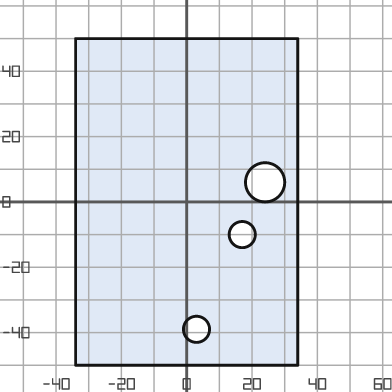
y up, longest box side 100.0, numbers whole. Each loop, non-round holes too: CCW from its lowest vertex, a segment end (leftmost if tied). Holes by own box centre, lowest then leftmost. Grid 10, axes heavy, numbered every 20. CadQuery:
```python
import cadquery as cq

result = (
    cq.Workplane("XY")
    .moveTo(-34.0, -50.0)
    .lineTo(34.0, -50.0)
    .lineTo(34.0, 50.0)
    .lineTo(-34.0, 50.0)
    .close()
    .moveTo(3.0, -39.0)
    .circle(4.0)
    .moveTo(17.0, -10.0)
    .circle(4.0)
    .moveTo(24.0, 6.0)
    .circle(6.0)
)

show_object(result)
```